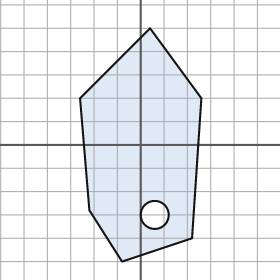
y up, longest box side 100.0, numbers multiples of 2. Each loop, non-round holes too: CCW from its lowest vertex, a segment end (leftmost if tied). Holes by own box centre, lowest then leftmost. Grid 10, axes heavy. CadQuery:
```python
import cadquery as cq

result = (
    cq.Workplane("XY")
    .moveTo(-8.0, -50.0)
    .lineTo(22.0, -40.0)
    .lineTo(26.0, 20.0)
    .lineTo(4.0, 50.0)
    .lineTo(-26.0, 20.0)
    .lineTo(-22.0, -28.0)
    .close()
    .moveTo(6.0, -30.0)
    .circle(6.0)
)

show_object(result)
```